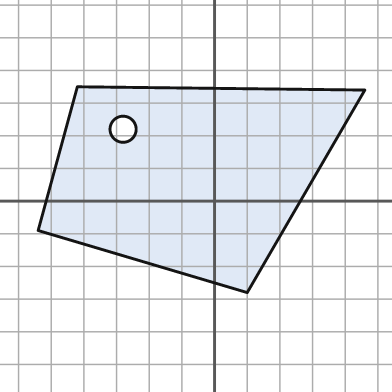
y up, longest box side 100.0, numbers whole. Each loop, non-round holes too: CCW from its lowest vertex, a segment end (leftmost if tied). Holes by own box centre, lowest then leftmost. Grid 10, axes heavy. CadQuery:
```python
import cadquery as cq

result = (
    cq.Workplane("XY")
    .moveTo(10.0, -28.0)
    .lineTo(46.0, 34.0)
    .lineTo(-42.0, 35.0)
    .lineTo(-54.0, -9.0)
    .close()
    .moveTo(-28.0, 22.0)
    .circle(4.0)
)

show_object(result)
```